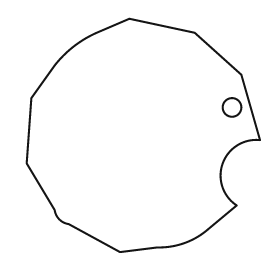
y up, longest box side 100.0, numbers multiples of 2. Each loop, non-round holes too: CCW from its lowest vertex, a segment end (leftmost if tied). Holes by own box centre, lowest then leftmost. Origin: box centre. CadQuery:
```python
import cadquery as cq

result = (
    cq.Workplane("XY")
    .moveTo(-10.0, -50.0)
    .lineTo(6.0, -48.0)
    .threePointArc((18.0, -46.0), (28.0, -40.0))
    .lineTo(40.0, -30.0)
    .threePointArc((34.0, -12.0), (50.0, -2.0))
    .lineTo(42.0, 26.0)
    .lineTo(22.0, 44.0)
    .lineTo(-6.0, 50.0)
    .lineTo(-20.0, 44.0)
    .threePointArc((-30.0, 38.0), (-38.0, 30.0))
    .lineTo(-48.0, 16.0)
    .lineTo(-50.0, -12.0)
    .lineTo(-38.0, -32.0)
    .threePointArc((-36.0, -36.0), (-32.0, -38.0))
    .close()
    .moveTo(38.0, 12.0)
    .circle(4.0)
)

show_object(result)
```